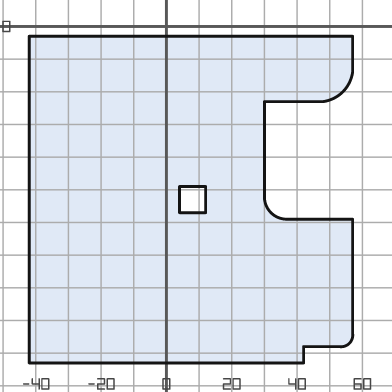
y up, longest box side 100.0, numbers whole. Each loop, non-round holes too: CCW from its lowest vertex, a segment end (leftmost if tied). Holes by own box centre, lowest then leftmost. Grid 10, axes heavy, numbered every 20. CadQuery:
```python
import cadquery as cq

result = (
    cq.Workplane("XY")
    .moveTo(-42.0, -103.0)
    .lineTo(42.0, -103.0)
    .lineTo(42.0, -98.0)
    .lineTo(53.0, -98.0)
    .threePointArc((56.0, -97.0), (57.0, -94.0))
    .lineTo(57.0, -59.0)
    .lineTo(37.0, -59.0)
    .threePointArc((32.0, -57.0), (30.0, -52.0))
    .lineTo(30.0, -23.0)
    .lineTo(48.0, -23.0)
    .threePointArc((54.0, -20.0), (57.0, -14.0))
    .lineTo(57.0, -3.0)
    .lineTo(-42.0, -3.0)
    .close()
    .moveTo(4.0, -57.0)
    .lineTo(12.0, -57.0)
    .lineTo(12.0, -49.0)
    .lineTo(4.0, -49.0)
    .close()
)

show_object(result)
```